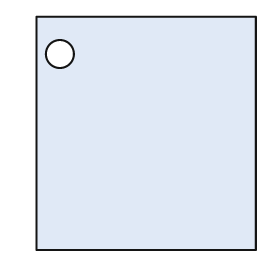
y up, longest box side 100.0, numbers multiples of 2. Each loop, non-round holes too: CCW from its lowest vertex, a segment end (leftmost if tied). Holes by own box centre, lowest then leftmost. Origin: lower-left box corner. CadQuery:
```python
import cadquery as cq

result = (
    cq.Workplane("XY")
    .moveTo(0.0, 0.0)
    .lineTo(94.0, 0.0)
    .lineTo(94.0, 100.0)
    .lineTo(0.0, 100.0)
    .close()
    .moveTo(10.0, 84.0)
    .circle(6.0)
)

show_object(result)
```